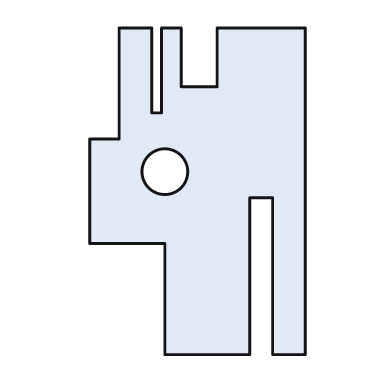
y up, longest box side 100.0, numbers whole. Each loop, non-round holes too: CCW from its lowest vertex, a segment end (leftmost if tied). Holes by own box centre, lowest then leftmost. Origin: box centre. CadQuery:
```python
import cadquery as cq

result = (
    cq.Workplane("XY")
    .moveTo(-10.0, -50.0)
    .lineTo(16.0, -50.0)
    .lineTo(16.0, -2.0)
    .lineTo(23.0, -2.0)
    .lineTo(23.0, -50.0)
    .lineTo(33.0, -50.0)
    .lineTo(33.0, 50.0)
    .lineTo(6.0, 50.0)
    .lineTo(6.0, 32.0)
    .lineTo(-5.0, 32.0)
    .lineTo(-5.0, 50.0)
    .lineTo(-11.0, 50.0)
    .lineTo(-11.0, 24.0)
    .lineTo(-14.0, 24.0)
    .lineTo(-14.0, 50.0)
    .lineTo(-24.0, 50.0)
    .lineTo(-24.0, 16.0)
    .lineTo(-33.0, 16.0)
    .lineTo(-33.0, -16.0)
    .lineTo(-10.0, -16.0)
    .close()
    .moveTo(-10.0, 6.0)
    .circle(7.0)
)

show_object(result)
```